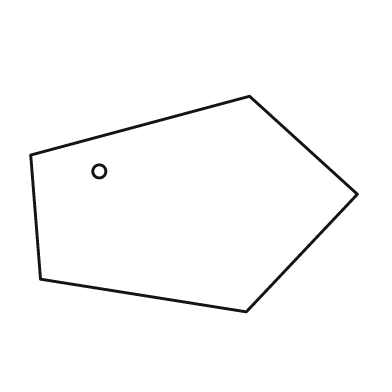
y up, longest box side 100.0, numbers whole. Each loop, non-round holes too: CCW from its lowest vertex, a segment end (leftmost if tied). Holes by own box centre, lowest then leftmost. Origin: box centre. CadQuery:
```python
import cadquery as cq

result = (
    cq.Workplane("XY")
    .moveTo(16.0, -33.0)
    .lineTo(50.0, 3.0)
    .lineTo(17.0, 33.0)
    .lineTo(-50.0, 15.0)
    .lineTo(-47.0, -23.0)
    .close()
    .moveTo(-29.0, 10.0)
    .circle(2.0)
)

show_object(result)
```